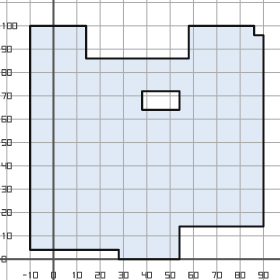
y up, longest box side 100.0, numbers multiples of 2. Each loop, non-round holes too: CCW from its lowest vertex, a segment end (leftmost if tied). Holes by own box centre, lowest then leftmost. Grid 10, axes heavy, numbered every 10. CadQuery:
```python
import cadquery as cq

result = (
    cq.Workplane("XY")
    .moveTo(28.0, 0.0)
    .lineTo(54.0, 0.0)
    .lineTo(54.0, 14.0)
    .lineTo(90.0, 14.0)
    .lineTo(90.0, 96.0)
    .lineTo(86.0, 96.0)
    .lineTo(86.0, 100.0)
    .lineTo(58.0, 100.0)
    .lineTo(58.0, 86.0)
    .lineTo(14.0, 86.0)
    .lineTo(14.0, 100.0)
    .lineTo(-10.0, 100.0)
    .lineTo(-10.0, 4.0)
    .lineTo(28.0, 4.0)
    .close()
    .moveTo(38.0, 64.0)
    .lineTo(54.0, 64.0)
    .lineTo(54.0, 72.0)
    .lineTo(38.0, 72.0)
    .close()
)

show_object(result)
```